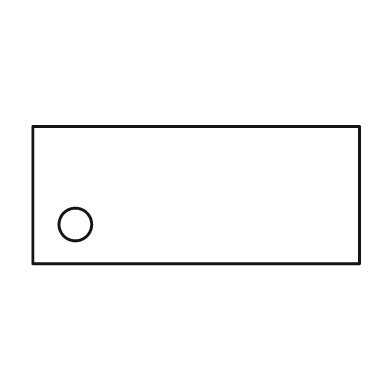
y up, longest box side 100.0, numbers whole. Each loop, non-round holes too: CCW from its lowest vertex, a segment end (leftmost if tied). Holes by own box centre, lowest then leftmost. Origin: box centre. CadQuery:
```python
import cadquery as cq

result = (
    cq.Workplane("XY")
    .moveTo(-50.0, -21.0)
    .lineTo(50.0, -21.0)
    .lineTo(50.0, 21.0)
    .lineTo(-50.0, 21.0)
    .close()
    .moveTo(-37.0, -9.0)
    .circle(5.0)
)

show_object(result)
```